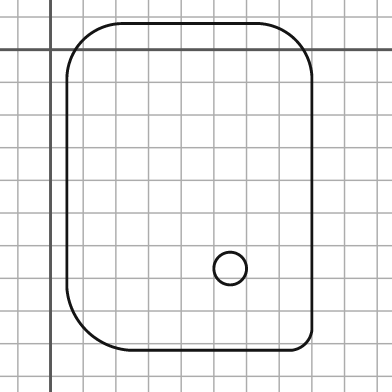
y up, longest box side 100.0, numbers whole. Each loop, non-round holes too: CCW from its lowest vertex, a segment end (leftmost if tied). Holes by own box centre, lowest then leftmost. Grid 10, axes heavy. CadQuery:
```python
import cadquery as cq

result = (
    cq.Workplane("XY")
    .moveTo(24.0, -92.0)
    .lineTo(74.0, -92.0)
    .threePointArc((78.0, -90.0), (80.0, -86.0))
    .lineTo(80.0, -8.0)
    .threePointArc((75.0, 3.0), (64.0, 8.0))
    .lineTo(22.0, 8.0)
    .threePointArc((10.0, 3.0), (5.0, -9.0))
    .lineTo(5.0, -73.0)
    .threePointArc((11.0, -86.0), (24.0, -92.0))
    .close()
    .moveTo(55.0, -67.0)
    .circle(5.0)
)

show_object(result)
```